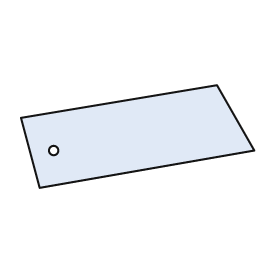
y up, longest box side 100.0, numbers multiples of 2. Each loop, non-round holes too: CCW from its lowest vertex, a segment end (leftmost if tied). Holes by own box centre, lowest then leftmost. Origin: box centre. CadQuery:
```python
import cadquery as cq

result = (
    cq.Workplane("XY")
    .moveTo(-42.0, -22.0)
    .lineTo(50.0, -6.0)
    .lineTo(34.0, 22.0)
    .lineTo(-50.0, 8.0)
    .close()
    .moveTo(-36.0, -6.0)
    .circle(2.0)
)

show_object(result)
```